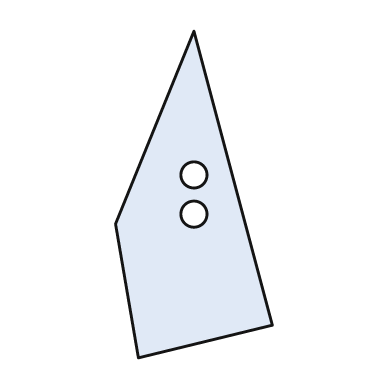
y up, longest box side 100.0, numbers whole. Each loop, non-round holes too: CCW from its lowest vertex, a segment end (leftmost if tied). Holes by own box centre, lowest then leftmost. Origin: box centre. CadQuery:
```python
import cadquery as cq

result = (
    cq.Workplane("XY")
    .moveTo(-17.0, -50.0)
    .lineTo(24.0, -40.0)
    .lineTo(0.0, 50.0)
    .lineTo(-24.0, -9.0)
    .close()
    .moveTo(0.0, -6.0)
    .circle(4.0)
    .moveTo(0.0, 6.0)
    .circle(4.0)
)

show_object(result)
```